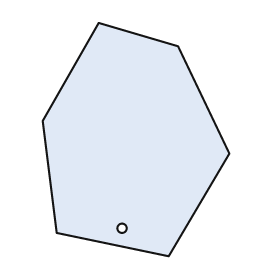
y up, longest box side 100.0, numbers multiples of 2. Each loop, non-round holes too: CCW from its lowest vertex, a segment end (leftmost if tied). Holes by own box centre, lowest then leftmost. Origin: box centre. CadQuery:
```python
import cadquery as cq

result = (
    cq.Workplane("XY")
    .moveTo(14.0, -50.0)
    .lineTo(40.0, -6.0)
    .lineTo(18.0, 40.0)
    .lineTo(-16.0, 50.0)
    .lineTo(-40.0, 8.0)
    .lineTo(-34.0, -40.0)
    .close()
    .moveTo(-6.0, -38.0)
    .circle(2.0)
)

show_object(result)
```